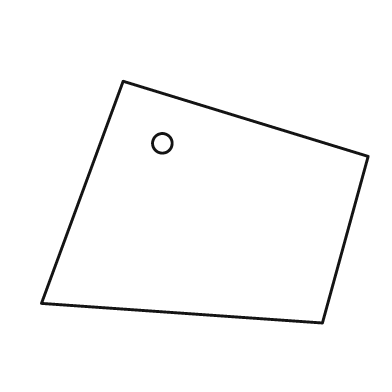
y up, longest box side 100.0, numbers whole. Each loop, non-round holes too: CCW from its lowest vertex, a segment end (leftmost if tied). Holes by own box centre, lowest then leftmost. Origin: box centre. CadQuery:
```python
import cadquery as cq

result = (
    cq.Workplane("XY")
    .moveTo(36.0, -37.0)
    .lineTo(50.0, 14.0)
    .lineTo(-25.0, 37.0)
    .lineTo(-50.0, -31.0)
    .close()
    .moveTo(-13.0, 18.0)
    .circle(3.0)
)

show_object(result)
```